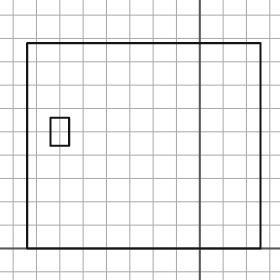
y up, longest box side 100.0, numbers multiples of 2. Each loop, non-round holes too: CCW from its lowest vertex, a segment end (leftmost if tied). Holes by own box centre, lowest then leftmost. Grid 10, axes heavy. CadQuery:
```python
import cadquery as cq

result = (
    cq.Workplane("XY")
    .moveTo(-74.0, 0.0)
    .lineTo(26.0, 0.0)
    .lineTo(26.0, 88.0)
    .lineTo(-74.0, 88.0)
    .close()
    .moveTo(-64.0, 44.0)
    .lineTo(-56.0, 44.0)
    .lineTo(-56.0, 56.0)
    .lineTo(-64.0, 56.0)
    .close()
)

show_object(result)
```